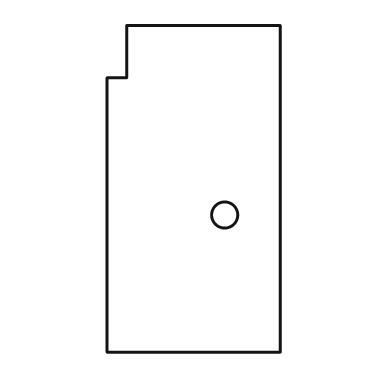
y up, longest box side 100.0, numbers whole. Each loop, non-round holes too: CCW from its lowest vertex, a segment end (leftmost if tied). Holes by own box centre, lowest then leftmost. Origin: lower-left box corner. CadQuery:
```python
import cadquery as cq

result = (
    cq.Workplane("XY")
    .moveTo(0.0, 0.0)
    .lineTo(53.0, 0.0)
    .lineTo(53.0, 100.0)
    .lineTo(6.0, 100.0)
    .lineTo(6.0, 84.0)
    .lineTo(0.0, 84.0)
    .close()
    .moveTo(36.0, 42.0)
    .circle(4.0)
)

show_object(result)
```